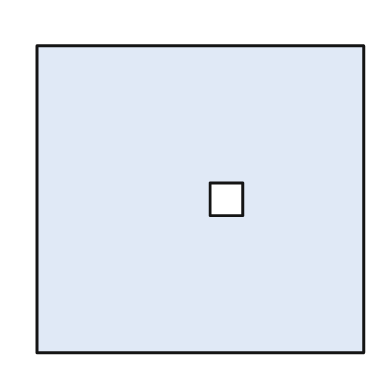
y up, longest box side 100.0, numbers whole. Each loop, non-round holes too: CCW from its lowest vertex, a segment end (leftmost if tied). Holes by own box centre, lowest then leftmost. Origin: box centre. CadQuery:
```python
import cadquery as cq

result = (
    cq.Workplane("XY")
    .moveTo(-50.0, -47.0)
    .lineTo(50.0, -47.0)
    .lineTo(50.0, 47.0)
    .lineTo(-50.0, 47.0)
    .close()
    .moveTo(3.0, -5.0)
    .lineTo(13.0, -5.0)
    .lineTo(13.0, 5.0)
    .lineTo(3.0, 5.0)
    .close()
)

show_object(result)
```